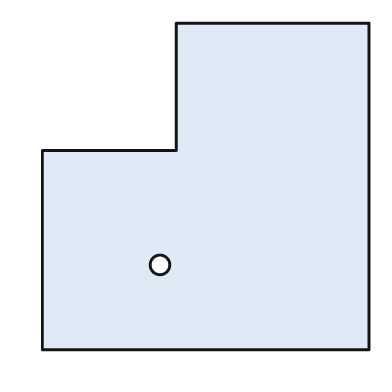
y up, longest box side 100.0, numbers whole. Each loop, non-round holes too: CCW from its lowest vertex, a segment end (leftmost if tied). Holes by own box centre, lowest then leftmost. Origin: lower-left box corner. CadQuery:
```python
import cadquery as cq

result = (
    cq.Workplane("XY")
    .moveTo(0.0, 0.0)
    .lineTo(100.0, 0.0)
    .lineTo(100.0, 100.0)
    .lineTo(41.0, 100.0)
    .lineTo(41.0, 61.0)
    .lineTo(0.0, 61.0)
    .close()
    .moveTo(36.0, 26.0)
    .circle(3.0)
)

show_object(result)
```